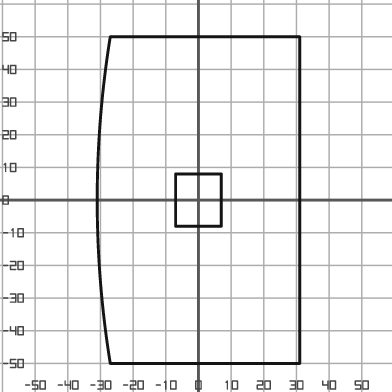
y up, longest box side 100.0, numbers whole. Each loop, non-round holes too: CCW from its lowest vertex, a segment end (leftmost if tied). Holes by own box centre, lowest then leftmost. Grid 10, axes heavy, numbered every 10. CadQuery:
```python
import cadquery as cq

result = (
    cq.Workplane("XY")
    .moveTo(-27.0, -50.0)
    .lineTo(31.0, -50.0)
    .lineTo(31.0, 50.0)
    .lineTo(-27.0, 50.0)
    .threePointArc((-31.0, 0.0), (-27.0, -50.0))
    .close()
    .moveTo(-7.0, -8.0)
    .lineTo(7.0, -8.0)
    .lineTo(7.0, 8.0)
    .lineTo(-7.0, 8.0)
    .close()
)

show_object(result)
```